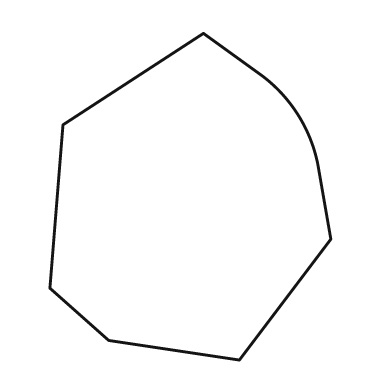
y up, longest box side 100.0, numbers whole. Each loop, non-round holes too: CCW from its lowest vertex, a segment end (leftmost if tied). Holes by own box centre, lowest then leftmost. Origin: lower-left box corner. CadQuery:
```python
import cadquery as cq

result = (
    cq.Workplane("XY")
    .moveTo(58.0, 0.0)
    .lineTo(86.0, 37.0)
    .lineTo(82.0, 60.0)
    .threePointArc((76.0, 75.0), (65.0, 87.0))
    .lineTo(47.0, 100.0)
    .lineTo(4.0, 72.0)
    .lineTo(0.0, 22.0)
    .lineTo(18.0, 6.0)
    .close()
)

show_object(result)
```